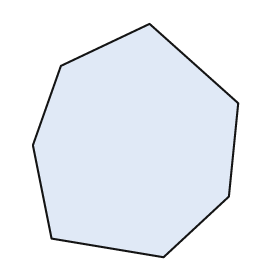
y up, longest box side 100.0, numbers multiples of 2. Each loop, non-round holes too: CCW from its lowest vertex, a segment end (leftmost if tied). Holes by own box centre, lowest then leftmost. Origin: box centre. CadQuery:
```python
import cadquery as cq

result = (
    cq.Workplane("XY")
    .moveTo(12.0, -50.0)
    .lineTo(40.0, -24.0)
    .lineTo(44.0, 16.0)
    .lineTo(6.0, 50.0)
    .lineTo(-32.0, 32.0)
    .lineTo(-44.0, -2.0)
    .lineTo(-36.0, -42.0)
    .close()
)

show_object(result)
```